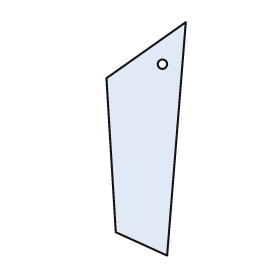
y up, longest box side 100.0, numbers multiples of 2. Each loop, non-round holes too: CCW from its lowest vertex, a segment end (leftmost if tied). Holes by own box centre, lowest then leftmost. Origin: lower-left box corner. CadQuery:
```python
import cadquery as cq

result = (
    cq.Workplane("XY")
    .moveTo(26.0, 0.0)
    .lineTo(34.0, 100.0)
    .lineTo(0.0, 76.0)
    .lineTo(4.0, 10.0)
    .close()
    .moveTo(24.0, 82.0)
    .circle(2.0)
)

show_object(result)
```